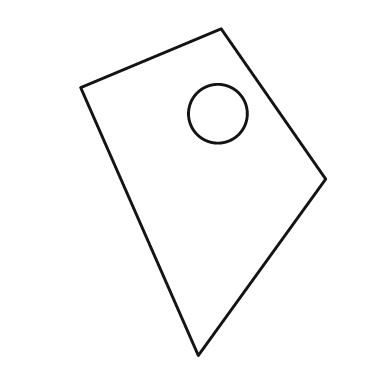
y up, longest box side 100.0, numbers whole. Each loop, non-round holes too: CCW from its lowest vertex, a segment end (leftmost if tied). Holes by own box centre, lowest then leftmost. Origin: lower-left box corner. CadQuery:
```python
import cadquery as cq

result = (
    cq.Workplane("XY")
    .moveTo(36.0, 0.0)
    .lineTo(75.0, 54.0)
    .lineTo(43.0, 100.0)
    .lineTo(0.0, 82.0)
    .close()
    .moveTo(42.0, 74.0)
    .circle(9.0)
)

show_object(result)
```